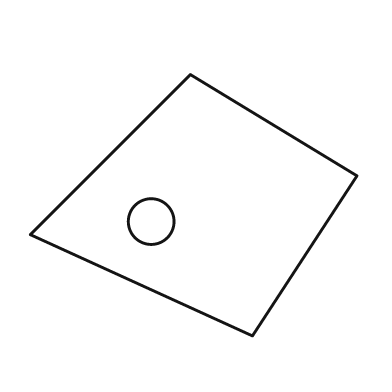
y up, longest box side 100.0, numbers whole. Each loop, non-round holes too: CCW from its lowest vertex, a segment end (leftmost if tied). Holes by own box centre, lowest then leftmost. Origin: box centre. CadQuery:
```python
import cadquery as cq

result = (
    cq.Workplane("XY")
    .moveTo(18.0, -40.0)
    .lineTo(50.0, 9.0)
    .lineTo(-1.0, 40.0)
    .lineTo(-50.0, -9.0)
    .close()
    .moveTo(-13.0, -5.0)
    .circle(7.0)
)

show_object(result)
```